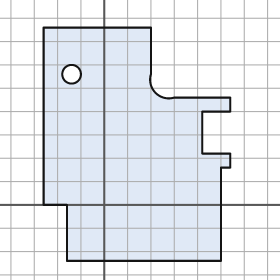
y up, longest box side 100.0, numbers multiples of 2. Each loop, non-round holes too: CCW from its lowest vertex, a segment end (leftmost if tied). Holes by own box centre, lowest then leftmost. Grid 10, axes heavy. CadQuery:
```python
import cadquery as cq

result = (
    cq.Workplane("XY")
    .moveTo(-16.0, -24.0)
    .lineTo(50.0, -24.0)
    .lineTo(50.0, 16.0)
    .lineTo(54.0, 16.0)
    .lineTo(54.0, 22.0)
    .lineTo(42.0, 22.0)
    .lineTo(42.0, 40.0)
    .lineTo(54.0, 40.0)
    .lineTo(54.0, 46.0)
    .lineTo(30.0, 46.0)
    .threePointArc((22.0, 48.0), (20.0, 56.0))
    .lineTo(20.0, 76.0)
    .lineTo(-26.0, 76.0)
    .lineTo(-26.0, 0.0)
    .lineTo(-16.0, 0.0)
    .close()
    .moveTo(-14.0, 56.0)
    .circle(4.0)
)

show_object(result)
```